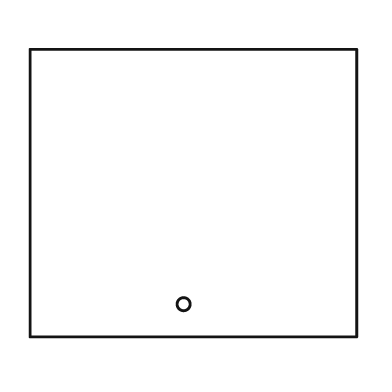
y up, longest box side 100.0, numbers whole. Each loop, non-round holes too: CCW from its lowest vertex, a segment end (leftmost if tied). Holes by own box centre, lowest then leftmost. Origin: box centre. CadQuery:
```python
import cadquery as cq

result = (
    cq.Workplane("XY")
    .moveTo(-50.0, -44.0)
    .lineTo(50.0, -44.0)
    .lineTo(50.0, 44.0)
    .lineTo(-50.0, 44.0)
    .close()
    .moveTo(-3.0, -34.0)
    .circle(2.0)
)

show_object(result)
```